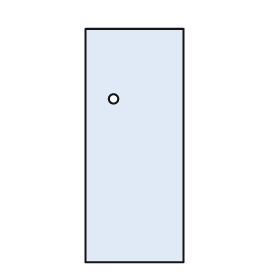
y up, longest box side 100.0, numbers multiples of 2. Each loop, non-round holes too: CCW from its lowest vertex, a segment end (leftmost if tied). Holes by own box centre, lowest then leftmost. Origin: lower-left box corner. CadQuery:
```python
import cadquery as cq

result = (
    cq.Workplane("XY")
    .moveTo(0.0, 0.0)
    .lineTo(42.0, 0.0)
    .lineTo(42.0, 100.0)
    .lineTo(0.0, 100.0)
    .close()
    .moveTo(12.0, 70.0)
    .circle(2.0)
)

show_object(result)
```